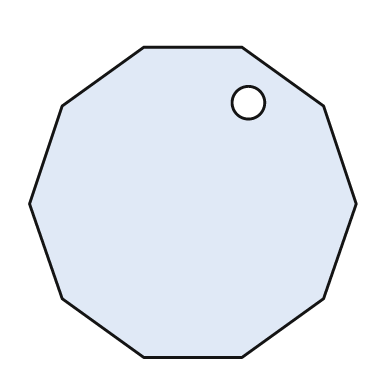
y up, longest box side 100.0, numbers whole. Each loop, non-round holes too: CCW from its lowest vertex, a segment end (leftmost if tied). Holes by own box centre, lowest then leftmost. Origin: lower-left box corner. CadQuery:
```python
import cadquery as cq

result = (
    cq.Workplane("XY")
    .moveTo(35.0, 0.0)
    .lineTo(65.0, 0.0)
    .lineTo(90.0, 18.0)
    .lineTo(100.0, 47.0)
    .lineTo(90.0, 77.0)
    .lineTo(65.0, 95.0)
    .lineTo(35.0, 95.0)
    .lineTo(10.0, 77.0)
    .lineTo(0.0, 47.0)
    .lineTo(10.0, 18.0)
    .close()
    .moveTo(67.0, 78.0)
    .circle(5.0)
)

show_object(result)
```